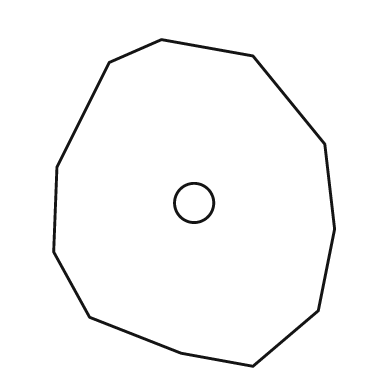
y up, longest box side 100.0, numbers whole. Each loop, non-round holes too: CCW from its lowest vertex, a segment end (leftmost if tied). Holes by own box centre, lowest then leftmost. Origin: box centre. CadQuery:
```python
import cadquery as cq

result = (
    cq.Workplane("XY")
    .moveTo(18.0, -50.0)
    .lineTo(38.0, -33.0)
    .lineTo(43.0, -8.0)
    .lineTo(40.0, 18.0)
    .lineTo(18.0, 45.0)
    .lineTo(-10.0, 50.0)
    .lineTo(-26.0, 43.0)
    .lineTo(-42.0, 11.0)
    .lineTo(-43.0, -15.0)
    .lineTo(-32.0, -35.0)
    .lineTo(-4.0, -46.0)
    .close()
    .moveTo(0.0, 0.0)
    .circle(6.0)
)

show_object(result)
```